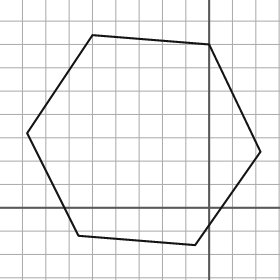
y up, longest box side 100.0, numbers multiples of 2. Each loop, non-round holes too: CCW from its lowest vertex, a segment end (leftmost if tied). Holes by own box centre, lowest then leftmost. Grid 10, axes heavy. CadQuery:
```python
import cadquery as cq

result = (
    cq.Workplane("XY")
    .moveTo(-6.0, -16.0)
    .lineTo(22.0, 24.0)
    .lineTo(0.0, 70.0)
    .lineTo(-50.0, 74.0)
    .lineTo(-78.0, 32.0)
    .lineTo(-56.0, -12.0)
    .close()
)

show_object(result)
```